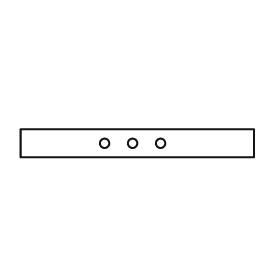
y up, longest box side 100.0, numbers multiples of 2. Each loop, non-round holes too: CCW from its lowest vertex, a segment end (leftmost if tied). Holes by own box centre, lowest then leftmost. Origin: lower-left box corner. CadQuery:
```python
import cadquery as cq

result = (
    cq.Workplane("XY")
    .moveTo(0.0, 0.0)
    .lineTo(100.0, 0.0)
    .lineTo(100.0, 12.0)
    .lineTo(0.0, 12.0)
    .close()
    .moveTo(36.0, 6.0)
    .circle(2.0)
    .moveTo(48.0, 6.0)
    .circle(2.0)
    .moveTo(60.0, 6.0)
    .circle(2.0)
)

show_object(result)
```